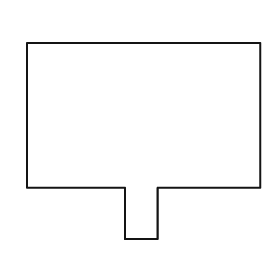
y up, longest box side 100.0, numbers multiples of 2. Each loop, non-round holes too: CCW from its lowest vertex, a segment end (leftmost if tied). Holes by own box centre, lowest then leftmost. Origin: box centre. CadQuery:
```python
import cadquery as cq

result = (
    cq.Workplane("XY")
    .moveTo(-8.0, -42.0)
    .lineTo(6.0, -42.0)
    .lineTo(6.0, -20.0)
    .lineTo(50.0, -20.0)
    .lineTo(50.0, 42.0)
    .lineTo(-50.0, 42.0)
    .lineTo(-50.0, -20.0)
    .lineTo(-8.0, -20.0)
    .close()
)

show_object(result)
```